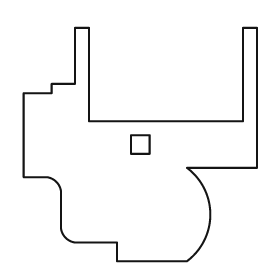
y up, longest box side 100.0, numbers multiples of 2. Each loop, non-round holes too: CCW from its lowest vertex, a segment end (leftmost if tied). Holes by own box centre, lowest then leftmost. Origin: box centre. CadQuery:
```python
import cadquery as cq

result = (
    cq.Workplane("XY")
    .moveTo(-10.0, -50.0)
    .lineTo(20.0, -50.0)
    .threePointArc((30.0, -30.0), (20.0, -10.0))
    .lineTo(50.0, -10.0)
    .lineTo(50.0, 50.0)
    .lineTo(44.0, 50.0)
    .lineTo(44.0, 10.0)
    .lineTo(-22.0, 10.0)
    .lineTo(-22.0, 50.0)
    .lineTo(-28.0, 50.0)
    .lineTo(-28.0, 26.0)
    .lineTo(-38.0, 26.0)
    .lineTo(-38.0, 22.0)
    .lineTo(-50.0, 22.0)
    .lineTo(-50.0, -14.0)
    .lineTo(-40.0, -14.0)
    .threePointArc((-36.0, -16.0), (-34.0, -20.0))
    .lineTo(-34.0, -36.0)
    .threePointArc((-32.0, -40.0), (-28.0, -42.0))
    .lineTo(-10.0, -42.0)
    .close()
    .moveTo(-4.0, -4.0)
    .lineTo(4.0, -4.0)
    .lineTo(4.0, 4.0)
    .lineTo(-4.0, 4.0)
    .close()
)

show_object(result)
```